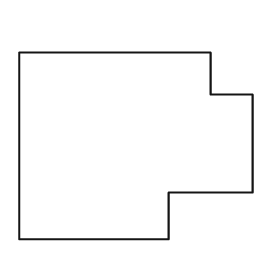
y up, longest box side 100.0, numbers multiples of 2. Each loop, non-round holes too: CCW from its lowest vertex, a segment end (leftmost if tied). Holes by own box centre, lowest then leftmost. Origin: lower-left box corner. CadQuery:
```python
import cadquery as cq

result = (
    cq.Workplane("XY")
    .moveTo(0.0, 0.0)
    .lineTo(64.0, 0.0)
    .lineTo(64.0, 20.0)
    .lineTo(100.0, 20.0)
    .lineTo(100.0, 62.0)
    .lineTo(82.0, 62.0)
    .lineTo(82.0, 80.0)
    .lineTo(0.0, 80.0)
    .close()
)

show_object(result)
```